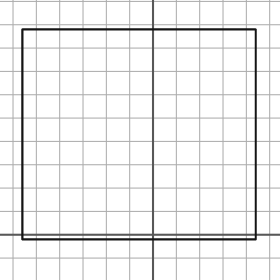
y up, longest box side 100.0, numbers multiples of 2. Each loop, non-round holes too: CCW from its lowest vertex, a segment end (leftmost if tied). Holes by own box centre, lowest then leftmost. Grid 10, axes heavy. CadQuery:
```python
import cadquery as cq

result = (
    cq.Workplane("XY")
    .moveTo(-56.0, -2.0)
    .lineTo(44.0, -2.0)
    .lineTo(44.0, 88.0)
    .lineTo(-56.0, 88.0)
    .close()
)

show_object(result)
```